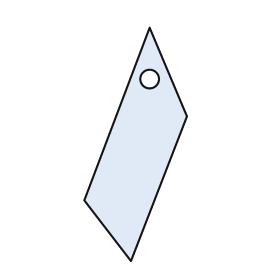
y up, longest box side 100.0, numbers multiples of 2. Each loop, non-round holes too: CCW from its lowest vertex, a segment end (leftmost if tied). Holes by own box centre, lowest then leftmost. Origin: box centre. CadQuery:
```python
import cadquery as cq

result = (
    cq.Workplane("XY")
    .moveTo(-2.0, -50.0)
    .lineTo(22.0, 12.0)
    .lineTo(6.0, 50.0)
    .lineTo(-22.0, -24.0)
    .close()
    .moveTo(6.0, 28.0)
    .circle(4.0)
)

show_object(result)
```